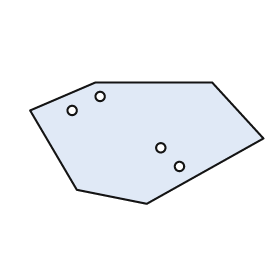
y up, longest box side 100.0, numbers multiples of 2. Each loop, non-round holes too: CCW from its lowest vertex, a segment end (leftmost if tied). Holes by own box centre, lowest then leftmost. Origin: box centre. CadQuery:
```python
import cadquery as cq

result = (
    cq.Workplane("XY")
    .moveTo(0.0, -26.0)
    .lineTo(50.0, 2.0)
    .lineTo(28.0, 26.0)
    .lineTo(-22.0, 26.0)
    .lineTo(-50.0, 14.0)
    .lineTo(-30.0, -20.0)
    .close()
    .moveTo(14.0, -10.0)
    .circle(2.0)
    .moveTo(6.0, -2.0)
    .circle(2.0)
    .moveTo(-32.0, 14.0)
    .circle(2.0)
    .moveTo(-20.0, 20.0)
    .circle(2.0)
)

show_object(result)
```